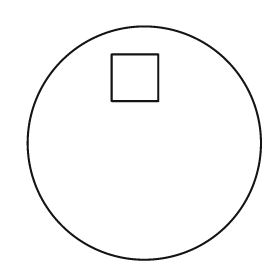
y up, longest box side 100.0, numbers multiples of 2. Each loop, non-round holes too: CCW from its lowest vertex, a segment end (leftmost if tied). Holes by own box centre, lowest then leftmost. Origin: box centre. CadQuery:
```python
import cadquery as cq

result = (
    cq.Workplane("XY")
    .moveTo(0.0, 0.0)
    .circle(50.0)
    .moveTo(-14.0, 18.0)
    .lineTo(6.0, 18.0)
    .lineTo(6.0, 38.0)
    .lineTo(-14.0, 38.0)
    .close()
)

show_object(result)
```